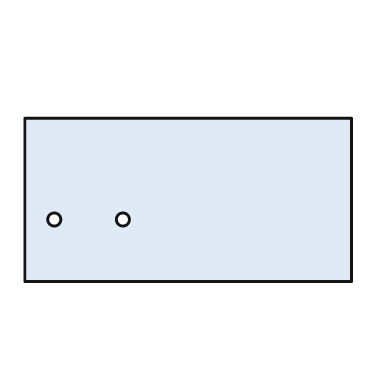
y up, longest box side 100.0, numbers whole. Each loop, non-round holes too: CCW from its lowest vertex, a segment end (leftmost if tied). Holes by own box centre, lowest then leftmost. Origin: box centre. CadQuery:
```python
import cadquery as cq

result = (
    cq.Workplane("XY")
    .moveTo(-50.0, -25.0)
    .lineTo(50.0, -25.0)
    .lineTo(50.0, 25.0)
    .lineTo(-50.0, 25.0)
    .close()
    .moveTo(-41.0, -6.0)
    .circle(2.0)
    .moveTo(-20.0, -6.0)
    .circle(2.0)
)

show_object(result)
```